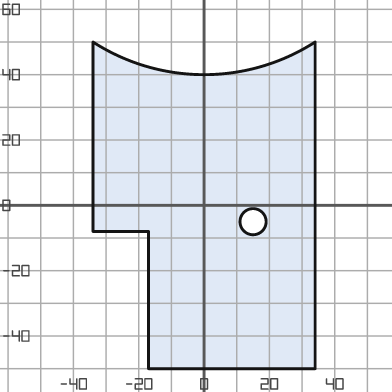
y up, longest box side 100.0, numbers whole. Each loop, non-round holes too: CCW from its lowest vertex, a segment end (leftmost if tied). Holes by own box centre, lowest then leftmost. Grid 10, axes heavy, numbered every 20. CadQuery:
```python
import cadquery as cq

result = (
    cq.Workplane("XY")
    .moveTo(-17.0, -50.0)
    .lineTo(34.0, -50.0)
    .lineTo(34.0, 50.0)
    .threePointArc((0.0, 40.0), (-34.0, 50.0))
    .lineTo(-34.0, -8.0)
    .lineTo(-17.0, -8.0)
    .close()
    .moveTo(15.0, -5.0)
    .circle(4.0)
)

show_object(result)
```